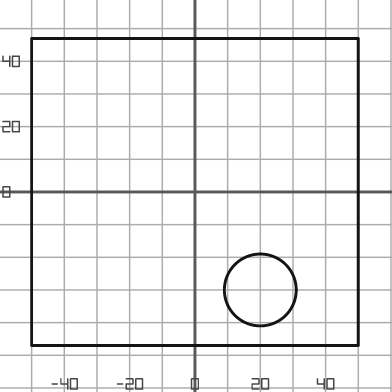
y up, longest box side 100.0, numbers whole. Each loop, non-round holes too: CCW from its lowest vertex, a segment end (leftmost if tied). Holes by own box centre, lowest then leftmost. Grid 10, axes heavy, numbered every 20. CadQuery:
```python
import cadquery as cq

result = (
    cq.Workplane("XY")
    .moveTo(-50.0, -47.0)
    .lineTo(50.0, -47.0)
    .lineTo(50.0, 47.0)
    .lineTo(-50.0, 47.0)
    .close()
    .moveTo(20.0, -30.0)
    .circle(11.0)
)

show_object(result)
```